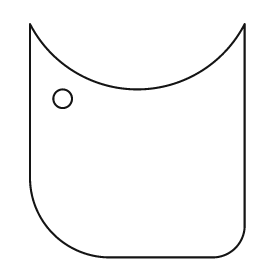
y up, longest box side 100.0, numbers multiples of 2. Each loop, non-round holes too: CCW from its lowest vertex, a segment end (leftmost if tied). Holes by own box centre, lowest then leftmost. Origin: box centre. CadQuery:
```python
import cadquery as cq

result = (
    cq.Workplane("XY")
    .moveTo(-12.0, -50.0)
    .lineTo(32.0, -50.0)
    .threePointArc((42.0, -46.0), (46.0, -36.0))
    .lineTo(46.0, 50.0)
    .threePointArc((0.0, 22.0), (-46.0, 50.0))
    .lineTo(-46.0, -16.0)
    .threePointArc((-36.0, -40.0), (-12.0, -50.0))
    .close()
    .moveTo(-32.0, 18.0)
    .circle(4.0)
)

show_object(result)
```